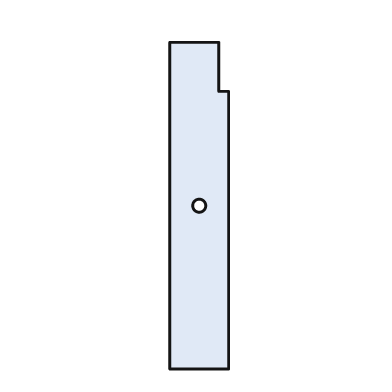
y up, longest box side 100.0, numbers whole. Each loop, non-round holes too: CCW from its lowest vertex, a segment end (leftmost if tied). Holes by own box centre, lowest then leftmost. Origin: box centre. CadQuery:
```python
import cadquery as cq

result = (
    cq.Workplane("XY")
    .moveTo(-9.0, -50.0)
    .lineTo(9.0, -50.0)
    .lineTo(9.0, 35.0)
    .lineTo(6.0, 35.0)
    .lineTo(6.0, 50.0)
    .lineTo(-9.0, 50.0)
    .close()
    .moveTo(0.0, 0.0)
    .circle(2.0)
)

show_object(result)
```